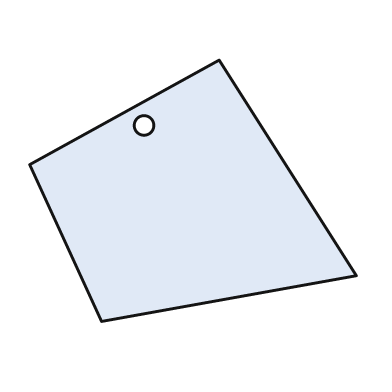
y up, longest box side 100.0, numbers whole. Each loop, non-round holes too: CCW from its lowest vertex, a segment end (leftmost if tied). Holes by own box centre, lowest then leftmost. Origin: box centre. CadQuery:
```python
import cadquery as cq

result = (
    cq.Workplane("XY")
    .moveTo(-28.0, -40.0)
    .lineTo(50.0, -26.0)
    .lineTo(8.0, 40.0)
    .lineTo(-50.0, 8.0)
    .close()
    .moveTo(-15.0, 20.0)
    .circle(3.0)
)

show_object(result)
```